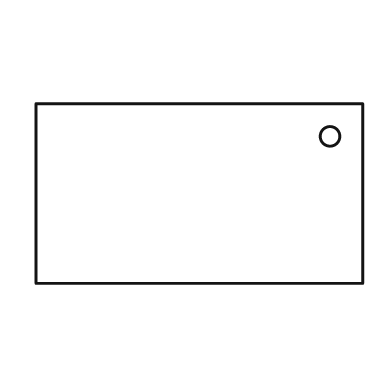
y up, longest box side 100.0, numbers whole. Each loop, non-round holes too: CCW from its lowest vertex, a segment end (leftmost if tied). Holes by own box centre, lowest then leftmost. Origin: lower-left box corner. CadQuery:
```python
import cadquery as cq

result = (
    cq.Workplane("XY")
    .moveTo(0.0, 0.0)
    .lineTo(100.0, 0.0)
    .lineTo(100.0, 55.0)
    .lineTo(0.0, 55.0)
    .close()
    .moveTo(90.0, 45.0)
    .circle(3.0)
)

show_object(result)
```